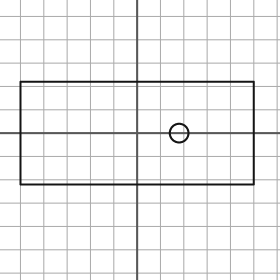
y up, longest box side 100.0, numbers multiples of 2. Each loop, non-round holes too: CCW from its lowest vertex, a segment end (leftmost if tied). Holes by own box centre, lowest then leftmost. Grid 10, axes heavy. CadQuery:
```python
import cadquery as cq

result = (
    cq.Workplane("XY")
    .moveTo(-50.0, -22.0)
    .lineTo(50.0, -22.0)
    .lineTo(50.0, 22.0)
    .lineTo(-50.0, 22.0)
    .close()
    .moveTo(18.0, 0.0)
    .circle(4.0)
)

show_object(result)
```